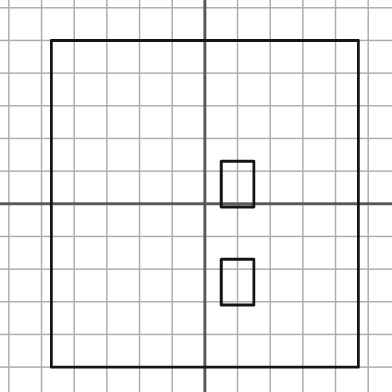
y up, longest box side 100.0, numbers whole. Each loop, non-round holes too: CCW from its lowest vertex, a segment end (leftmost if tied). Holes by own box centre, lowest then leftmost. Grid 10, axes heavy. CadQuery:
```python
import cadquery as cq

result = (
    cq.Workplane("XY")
    .moveTo(-47.0, -50.0)
    .lineTo(47.0, -50.0)
    .lineTo(47.0, 50.0)
    .lineTo(-47.0, 50.0)
    .close()
    .moveTo(5.0, -31.0)
    .lineTo(15.0, -31.0)
    .lineTo(15.0, -17.0)
    .lineTo(5.0, -17.0)
    .close()
    .moveTo(5.0, -1.0)
    .lineTo(15.0, -1.0)
    .lineTo(15.0, 13.0)
    .lineTo(5.0, 13.0)
    .close()
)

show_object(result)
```